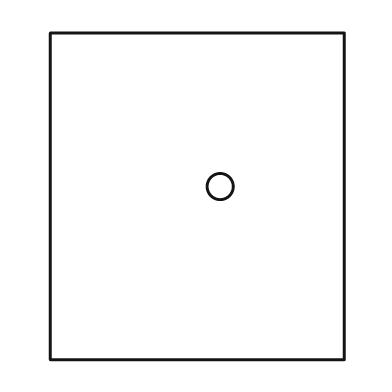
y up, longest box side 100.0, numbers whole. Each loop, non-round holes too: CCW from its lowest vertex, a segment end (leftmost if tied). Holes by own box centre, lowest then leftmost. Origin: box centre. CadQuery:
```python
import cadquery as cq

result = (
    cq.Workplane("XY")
    .moveTo(-45.0, -50.0)
    .lineTo(45.0, -50.0)
    .lineTo(45.0, 50.0)
    .lineTo(-45.0, 50.0)
    .close()
    .moveTo(7.0, 3.0)
    .circle(4.0)
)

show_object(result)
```